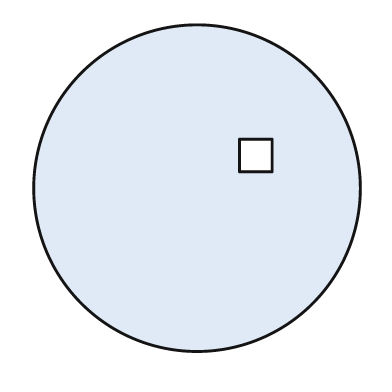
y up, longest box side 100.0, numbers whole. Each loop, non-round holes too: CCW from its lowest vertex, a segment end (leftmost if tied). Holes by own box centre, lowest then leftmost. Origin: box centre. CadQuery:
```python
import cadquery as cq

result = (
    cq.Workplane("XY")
    .moveTo(0.0, 0.0)
    .circle(50.0)
    .moveTo(13.0, 5.0)
    .lineTo(23.0, 5.0)
    .lineTo(23.0, 15.0)
    .lineTo(13.0, 15.0)
    .close()
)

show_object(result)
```